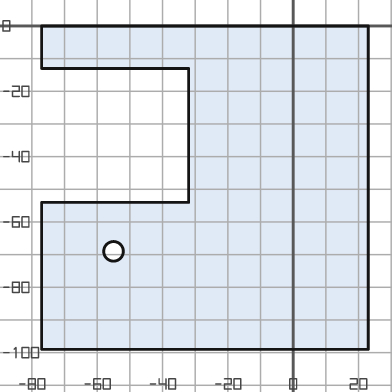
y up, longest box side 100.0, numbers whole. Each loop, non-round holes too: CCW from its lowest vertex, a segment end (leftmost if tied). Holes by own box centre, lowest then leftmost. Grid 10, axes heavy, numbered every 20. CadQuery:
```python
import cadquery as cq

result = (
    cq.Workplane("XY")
    .moveTo(-77.0, -99.0)
    .lineTo(23.0, -99.0)
    .lineTo(23.0, 0.0)
    .lineTo(-77.0, 0.0)
    .lineTo(-77.0, -13.0)
    .lineTo(-32.0, -13.0)
    .lineTo(-32.0, -54.0)
    .lineTo(-77.0, -54.0)
    .close()
    .moveTo(-55.0, -69.0)
    .circle(3.0)
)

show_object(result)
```